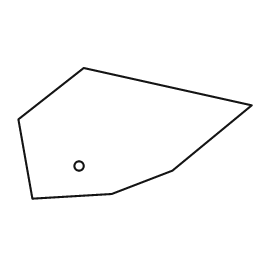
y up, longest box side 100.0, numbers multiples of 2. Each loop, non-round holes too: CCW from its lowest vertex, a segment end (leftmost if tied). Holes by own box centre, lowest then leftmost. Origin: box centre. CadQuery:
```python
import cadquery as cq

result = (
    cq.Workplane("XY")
    .moveTo(-44.0, -28.0)
    .lineTo(-10.0, -26.0)
    .lineTo(16.0, -16.0)
    .lineTo(50.0, 12.0)
    .lineTo(-22.0, 28.0)
    .lineTo(-50.0, 6.0)
    .close()
    .moveTo(-24.0, -14.0)
    .circle(2.0)
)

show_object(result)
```